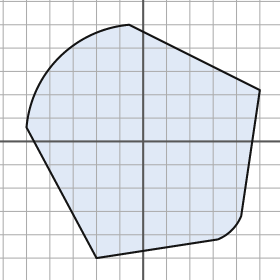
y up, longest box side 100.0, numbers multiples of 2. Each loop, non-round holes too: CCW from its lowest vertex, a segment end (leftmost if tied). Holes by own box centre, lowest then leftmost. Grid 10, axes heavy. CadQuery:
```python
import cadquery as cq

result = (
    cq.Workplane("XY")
    .moveTo(-20.0, -50.0)
    .lineTo(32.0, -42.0)
    .threePointArc((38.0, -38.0), (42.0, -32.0))
    .lineTo(50.0, 22.0)
    .lineTo(-6.0, 50.0)
    .threePointArc((-36.0, 36.0), (-50.0, 6.0))
    .close()
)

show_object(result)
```